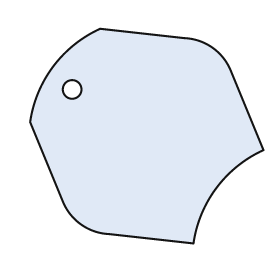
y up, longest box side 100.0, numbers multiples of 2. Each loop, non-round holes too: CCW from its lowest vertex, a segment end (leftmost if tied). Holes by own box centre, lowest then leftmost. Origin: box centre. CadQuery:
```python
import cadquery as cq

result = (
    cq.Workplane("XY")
    .moveTo(20.0, -46.0)
    .threePointArc((30.0, -22.0), (50.0, -6.0))
    .lineTo(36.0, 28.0)
    .threePointArc((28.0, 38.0), (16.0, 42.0))
    .lineTo(-20.0, 46.0)
    .threePointArc((-40.0, 30.0), (-50.0, 6.0))
    .lineTo(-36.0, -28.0)
    .threePointArc((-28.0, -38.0), (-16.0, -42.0))
    .close()
    .moveTo(-32.0, 20.0)
    .circle(4.0)
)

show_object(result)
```